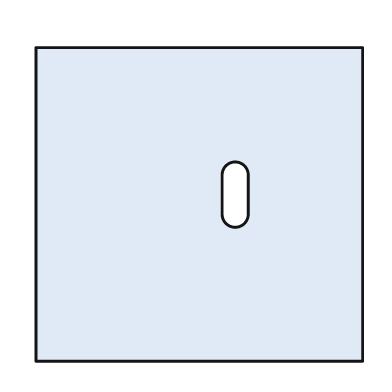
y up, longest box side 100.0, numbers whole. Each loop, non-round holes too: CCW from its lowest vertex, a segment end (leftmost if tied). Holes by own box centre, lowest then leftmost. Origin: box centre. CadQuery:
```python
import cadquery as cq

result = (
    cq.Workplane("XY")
    .moveTo(-50.0, -48.0)
    .lineTo(50.0, -48.0)
    .lineTo(50.0, 48.0)
    .lineTo(-50.0, 48.0)
    .close()
    .moveTo(7.0, -3.0)
    .threePointArc((11.0, -7.0), (15.0, -3.0))
    .lineTo(15.0, 9.0)
    .threePointArc((11.0, 13.0), (7.0, 9.0))
    .close()
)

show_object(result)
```